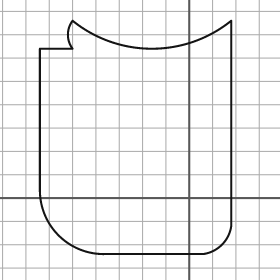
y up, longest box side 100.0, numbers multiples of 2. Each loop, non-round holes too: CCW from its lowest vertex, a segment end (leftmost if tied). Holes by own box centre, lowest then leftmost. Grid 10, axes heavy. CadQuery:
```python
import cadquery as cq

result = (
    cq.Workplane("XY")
    .moveTo(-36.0, -24.0)
    .lineTo(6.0, -24.0)
    .threePointArc((14.0, -20.0), (18.0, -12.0))
    .lineTo(18.0, 76.0)
    .threePointArc((-16.0, 64.0), (-50.0, 76.0))
    .threePointArc((-52.0, 70.0), (-50.0, 64.0))
    .lineTo(-64.0, 64.0)
    .lineTo(-64.0, 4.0)
    .threePointArc((-56.0, -16.0), (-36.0, -24.0))
    .close()
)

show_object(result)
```